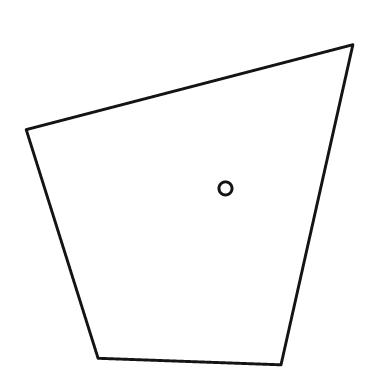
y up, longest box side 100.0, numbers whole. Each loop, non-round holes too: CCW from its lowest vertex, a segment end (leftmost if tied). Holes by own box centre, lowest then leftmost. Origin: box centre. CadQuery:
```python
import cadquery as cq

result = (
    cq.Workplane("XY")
    .moveTo(28.0, -49.0)
    .lineTo(50.0, 49.0)
    .lineTo(-50.0, 23.0)
    .lineTo(-28.0, -47.0)
    .close()
    .moveTo(11.0, 5.0)
    .circle(2.0)
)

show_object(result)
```